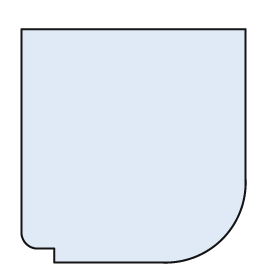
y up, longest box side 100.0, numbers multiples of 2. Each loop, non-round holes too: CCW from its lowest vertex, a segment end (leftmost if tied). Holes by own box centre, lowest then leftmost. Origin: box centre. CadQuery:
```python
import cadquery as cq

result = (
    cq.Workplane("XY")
    .moveTo(-34.0, -50.0)
    .lineTo(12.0, -50.0)
    .threePointArc((38.0, -40.0), (48.0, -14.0))
    .lineTo(48.0, 50.0)
    .lineTo(-48.0, 50.0)
    .lineTo(-48.0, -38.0)
    .threePointArc((-46.0, -42.0), (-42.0, -44.0))
    .lineTo(-34.0, -44.0)
    .close()
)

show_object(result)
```